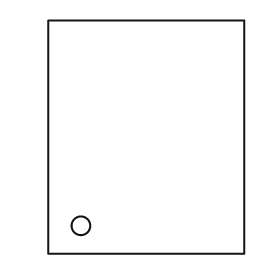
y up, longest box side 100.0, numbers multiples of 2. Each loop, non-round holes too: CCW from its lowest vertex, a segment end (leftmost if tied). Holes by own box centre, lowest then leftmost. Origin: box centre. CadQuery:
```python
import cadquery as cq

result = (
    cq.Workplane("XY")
    .moveTo(-42.0, -50.0)
    .lineTo(42.0, -50.0)
    .lineTo(42.0, 50.0)
    .lineTo(-42.0, 50.0)
    .close()
    .moveTo(-28.0, -38.0)
    .circle(4.0)
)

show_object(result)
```